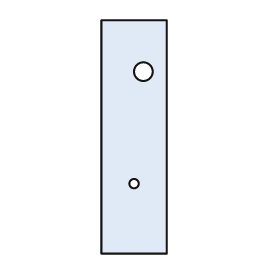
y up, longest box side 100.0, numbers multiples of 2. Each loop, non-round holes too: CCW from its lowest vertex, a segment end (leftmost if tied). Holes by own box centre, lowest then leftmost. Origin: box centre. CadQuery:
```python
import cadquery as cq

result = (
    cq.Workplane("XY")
    .moveTo(-14.0, -50.0)
    .lineTo(14.0, -50.0)
    .lineTo(14.0, 50.0)
    .lineTo(-14.0, 50.0)
    .close()
    .moveTo(0.0, -20.0)
    .circle(2.0)
    .moveTo(4.0, 28.0)
    .circle(4.0)
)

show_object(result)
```